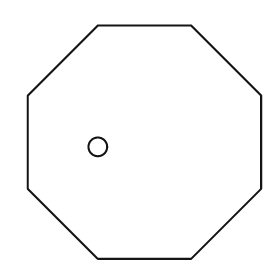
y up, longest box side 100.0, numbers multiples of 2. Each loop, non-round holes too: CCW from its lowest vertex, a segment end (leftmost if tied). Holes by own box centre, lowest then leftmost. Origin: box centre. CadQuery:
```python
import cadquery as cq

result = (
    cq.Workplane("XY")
    .moveTo(-20.0, -50.0)
    .lineTo(20.0, -50.0)
    .lineTo(50.0, -20.0)
    .lineTo(50.0, 20.0)
    .lineTo(20.0, 50.0)
    .lineTo(-20.0, 50.0)
    .lineTo(-50.0, 20.0)
    .lineTo(-50.0, -20.0)
    .close()
    .moveTo(-20.0, -2.0)
    .circle(4.0)
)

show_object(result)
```